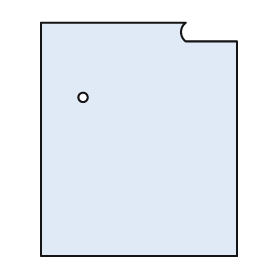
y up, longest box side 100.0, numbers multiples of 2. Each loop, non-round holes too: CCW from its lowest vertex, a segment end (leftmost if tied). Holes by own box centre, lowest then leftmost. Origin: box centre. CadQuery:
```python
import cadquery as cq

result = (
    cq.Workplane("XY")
    .moveTo(-42.0, -50.0)
    .lineTo(42.0, -50.0)
    .lineTo(42.0, 42.0)
    .lineTo(20.0, 42.0)
    .threePointArc((18.0, 46.0), (20.0, 50.0))
    .lineTo(-42.0, 50.0)
    .close()
    .moveTo(-24.0, 18.0)
    .circle(2.0)
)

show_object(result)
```